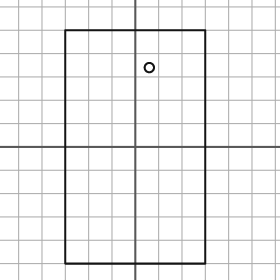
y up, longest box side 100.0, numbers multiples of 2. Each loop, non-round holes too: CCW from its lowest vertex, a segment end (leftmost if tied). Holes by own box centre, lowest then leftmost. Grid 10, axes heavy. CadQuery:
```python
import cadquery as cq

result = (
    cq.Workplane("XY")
    .moveTo(-30.0, -50.0)
    .lineTo(30.0, -50.0)
    .lineTo(30.0, 50.0)
    .lineTo(-30.0, 50.0)
    .close()
    .moveTo(6.0, 34.0)
    .circle(2.0)
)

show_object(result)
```